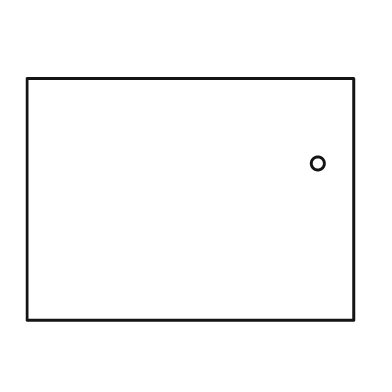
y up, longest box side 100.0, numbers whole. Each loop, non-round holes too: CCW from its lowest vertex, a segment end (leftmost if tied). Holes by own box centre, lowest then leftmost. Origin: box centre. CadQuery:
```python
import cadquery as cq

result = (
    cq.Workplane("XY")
    .moveTo(-50.0, -37.0)
    .lineTo(50.0, -37.0)
    .lineTo(50.0, 37.0)
    .lineTo(-50.0, 37.0)
    .close()
    .moveTo(39.0, 11.0)
    .circle(2.0)
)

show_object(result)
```